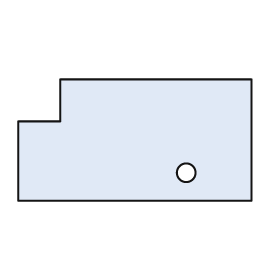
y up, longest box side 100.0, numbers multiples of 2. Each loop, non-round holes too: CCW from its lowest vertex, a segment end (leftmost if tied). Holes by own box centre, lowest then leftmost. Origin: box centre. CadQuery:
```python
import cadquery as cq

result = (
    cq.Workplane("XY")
    .moveTo(-50.0, -26.0)
    .lineTo(50.0, -26.0)
    .lineTo(50.0, 26.0)
    .lineTo(-32.0, 26.0)
    .lineTo(-32.0, 8.0)
    .lineTo(-50.0, 8.0)
    .close()
    .moveTo(22.0, -14.0)
    .circle(4.0)
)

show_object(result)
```